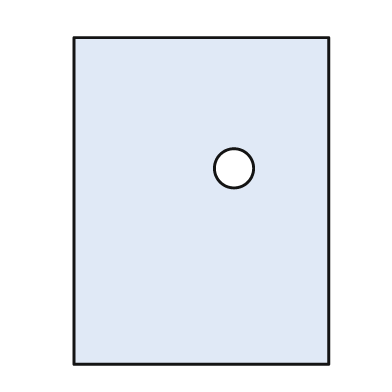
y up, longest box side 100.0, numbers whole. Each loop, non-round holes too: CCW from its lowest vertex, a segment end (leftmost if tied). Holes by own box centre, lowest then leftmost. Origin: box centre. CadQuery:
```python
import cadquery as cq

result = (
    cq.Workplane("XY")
    .moveTo(-39.0, -50.0)
    .lineTo(39.0, -50.0)
    .lineTo(39.0, 50.0)
    .lineTo(-39.0, 50.0)
    .close()
    .moveTo(10.0, 10.0)
    .circle(6.0)
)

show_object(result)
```